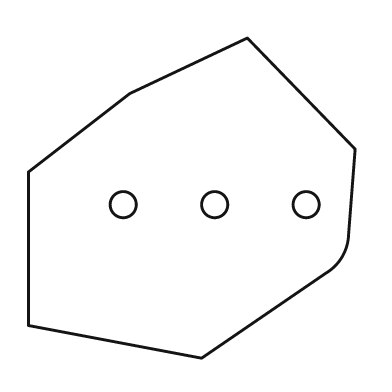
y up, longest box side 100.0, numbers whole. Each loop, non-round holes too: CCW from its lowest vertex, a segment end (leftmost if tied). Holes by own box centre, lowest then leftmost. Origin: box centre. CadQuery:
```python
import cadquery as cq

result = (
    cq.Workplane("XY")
    .moveTo(3.0, -49.0)
    .lineTo(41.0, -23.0)
    .threePointArc((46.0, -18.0), (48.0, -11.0))
    .lineTo(50.0, 15.0)
    .lineTo(17.0, 49.0)
    .lineTo(-19.0, 32.0)
    .lineTo(-50.0, 8.0)
    .lineTo(-50.0, -39.0)
    .close()
    .moveTo(-21.0, -2.0)
    .circle(4.0)
    .moveTo(7.0, -2.0)
    .circle(4.0)
    .moveTo(35.0, -2.0)
    .circle(4.0)
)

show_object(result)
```